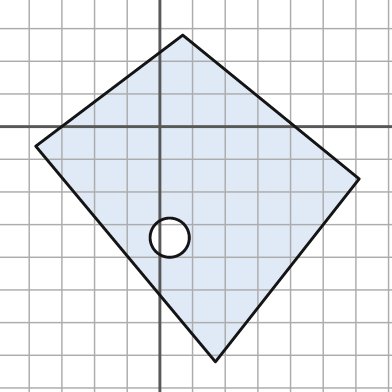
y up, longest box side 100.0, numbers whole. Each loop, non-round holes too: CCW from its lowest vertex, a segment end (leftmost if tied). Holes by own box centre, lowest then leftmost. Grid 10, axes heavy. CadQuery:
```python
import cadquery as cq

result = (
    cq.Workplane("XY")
    .moveTo(17.0, -72.0)
    .lineTo(61.0, -16.0)
    .lineTo(7.0, 28.0)
    .lineTo(-38.0, -6.0)
    .close()
    .moveTo(3.0, -34.0)
    .circle(6.0)
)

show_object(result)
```